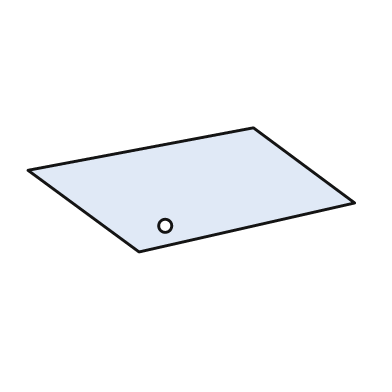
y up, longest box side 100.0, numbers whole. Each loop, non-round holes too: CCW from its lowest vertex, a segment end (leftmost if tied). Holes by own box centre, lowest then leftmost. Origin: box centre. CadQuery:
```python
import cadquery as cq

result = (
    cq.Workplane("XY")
    .moveTo(-16.0, -19.0)
    .lineTo(50.0, -4.0)
    .lineTo(19.0, 19.0)
    .lineTo(-50.0, 6.0)
    .close()
    .moveTo(-8.0, -11.0)
    .circle(2.0)
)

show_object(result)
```